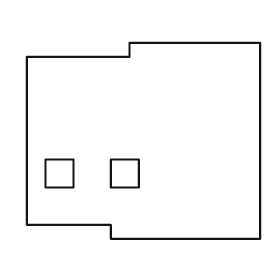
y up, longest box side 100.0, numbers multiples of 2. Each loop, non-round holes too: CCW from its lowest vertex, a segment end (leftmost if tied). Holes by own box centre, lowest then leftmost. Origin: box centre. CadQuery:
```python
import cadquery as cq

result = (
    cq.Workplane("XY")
    .moveTo(-14.0, -42.0)
    .lineTo(50.0, -42.0)
    .lineTo(50.0, 42.0)
    .lineTo(-6.0, 42.0)
    .lineTo(-6.0, 36.0)
    .lineTo(-50.0, 36.0)
    .lineTo(-50.0, -36.0)
    .lineTo(-14.0, -36.0)
    .close()
    .moveTo(-42.0, -20.0)
    .lineTo(-30.0, -20.0)
    .lineTo(-30.0, -8.0)
    .lineTo(-42.0, -8.0)
    .close()
    .moveTo(-14.0, -20.0)
    .lineTo(-2.0, -20.0)
    .lineTo(-2.0, -8.0)
    .lineTo(-14.0, -8.0)
    .close()
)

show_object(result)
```